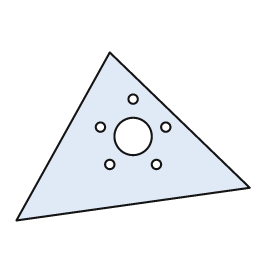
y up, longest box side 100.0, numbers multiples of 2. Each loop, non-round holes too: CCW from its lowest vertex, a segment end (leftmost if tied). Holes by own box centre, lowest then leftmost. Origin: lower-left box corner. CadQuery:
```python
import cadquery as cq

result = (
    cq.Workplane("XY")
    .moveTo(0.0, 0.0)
    .lineTo(100.0, 14.0)
    .lineTo(40.0, 72.0)
    .close()
    .moveTo(40.0, 24.0)
    .circle(2.0)
    .moveTo(60.0, 24.0)
    .circle(2.0)
    .moveTo(50.0, 36.0)
    .circle(8.0)
    .moveTo(36.0, 40.0)
    .circle(2.0)
    .moveTo(64.0, 40.0)
    .circle(2.0)
    .moveTo(50.0, 52.0)
    .circle(2.0)
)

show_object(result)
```